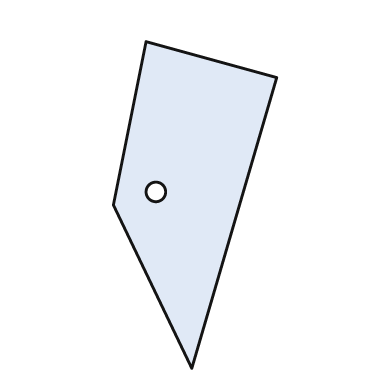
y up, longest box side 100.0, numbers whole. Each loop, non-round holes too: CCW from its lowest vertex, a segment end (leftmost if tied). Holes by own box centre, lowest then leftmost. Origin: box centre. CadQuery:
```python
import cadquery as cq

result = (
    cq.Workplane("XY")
    .moveTo(-1.0, -50.0)
    .lineTo(25.0, 39.0)
    .lineTo(-15.0, 50.0)
    .lineTo(-25.0, 0.0)
    .close()
    .moveTo(-12.0, 4.0)
    .circle(3.0)
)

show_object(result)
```